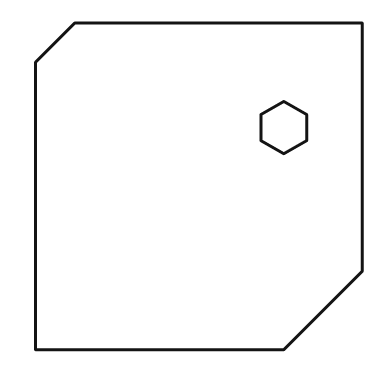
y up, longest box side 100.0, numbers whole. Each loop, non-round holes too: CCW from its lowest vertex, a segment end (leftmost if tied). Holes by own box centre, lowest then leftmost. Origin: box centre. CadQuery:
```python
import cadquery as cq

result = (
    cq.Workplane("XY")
    .moveTo(-50.0, -50.0)
    .lineTo(26.0, -50.0)
    .lineTo(50.0, -26.0)
    .lineTo(50.0, 50.0)
    .lineTo(-38.0, 50.0)
    .lineTo(-50.0, 38.0)
    .close()
    .moveTo(26.0, 10.0)
    .lineTo(33.0, 14.0)
    .lineTo(33.0, 22.0)
    .lineTo(26.0, 26.0)
    .lineTo(19.0, 22.0)
    .lineTo(19.0, 14.0)
    .close()
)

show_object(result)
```